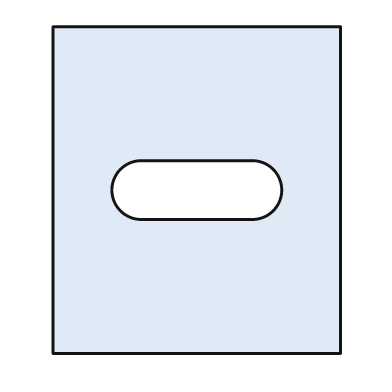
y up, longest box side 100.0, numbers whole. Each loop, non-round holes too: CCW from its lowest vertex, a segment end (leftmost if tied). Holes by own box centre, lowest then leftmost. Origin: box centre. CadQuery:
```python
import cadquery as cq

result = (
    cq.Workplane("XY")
    .moveTo(-44.0, -50.0)
    .lineTo(44.0, -50.0)
    .lineTo(44.0, 50.0)
    .lineTo(-44.0, 50.0)
    .close()
    .moveTo(-17.0, -9.0)
    .lineTo(17.0, -9.0)
    .threePointArc((26.0, 0.0), (17.0, 9.0))
    .lineTo(-17.0, 9.0)
    .threePointArc((-26.0, 0.0), (-17.0, -9.0))
    .close()
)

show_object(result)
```